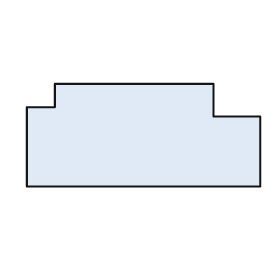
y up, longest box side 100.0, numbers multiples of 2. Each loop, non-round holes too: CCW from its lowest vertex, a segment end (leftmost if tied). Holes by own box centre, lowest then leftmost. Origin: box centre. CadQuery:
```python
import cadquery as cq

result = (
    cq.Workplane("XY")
    .moveTo(-50.0, -22.0)
    .lineTo(50.0, -22.0)
    .lineTo(50.0, 8.0)
    .lineTo(30.0, 8.0)
    .lineTo(30.0, 22.0)
    .lineTo(-38.0, 22.0)
    .lineTo(-38.0, 12.0)
    .lineTo(-50.0, 12.0)
    .close()
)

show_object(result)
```